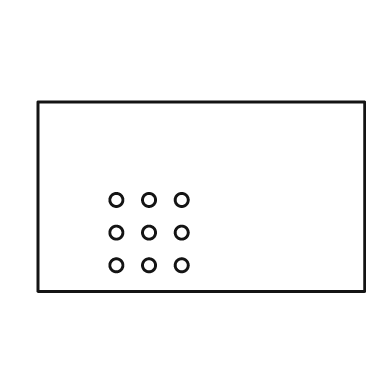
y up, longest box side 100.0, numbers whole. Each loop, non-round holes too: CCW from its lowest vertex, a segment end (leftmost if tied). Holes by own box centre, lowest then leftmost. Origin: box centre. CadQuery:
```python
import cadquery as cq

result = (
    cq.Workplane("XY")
    .moveTo(-50.0, -29.0)
    .lineTo(50.0, -29.0)
    .lineTo(50.0, 29.0)
    .lineTo(-50.0, 29.0)
    .close()
    .moveTo(-26.0, -21.0)
    .circle(2.0)
    .moveTo(-16.0, -21.0)
    .circle(2.0)
    .moveTo(-6.0, -21.0)
    .circle(2.0)
    .moveTo(-26.0, -11.0)
    .circle(2.0)
    .moveTo(-16.0, -11.0)
    .circle(2.0)
    .moveTo(-6.0, -11.0)
    .circle(2.0)
    .moveTo(-26.0, -1.0)
    .circle(2.0)
    .moveTo(-16.0, -1.0)
    .circle(2.0)
    .moveTo(-6.0, -1.0)
    .circle(2.0)
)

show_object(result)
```